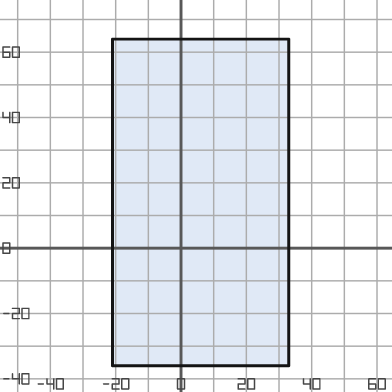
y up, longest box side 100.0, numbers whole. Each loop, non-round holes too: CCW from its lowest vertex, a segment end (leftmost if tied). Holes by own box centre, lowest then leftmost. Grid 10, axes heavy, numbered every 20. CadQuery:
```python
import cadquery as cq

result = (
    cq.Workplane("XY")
    .moveTo(-21.0, -36.0)
    .lineTo(33.0, -36.0)
    .lineTo(33.0, 64.0)
    .lineTo(-21.0, 64.0)
    .close()
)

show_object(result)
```